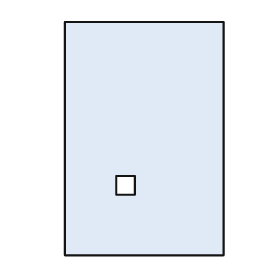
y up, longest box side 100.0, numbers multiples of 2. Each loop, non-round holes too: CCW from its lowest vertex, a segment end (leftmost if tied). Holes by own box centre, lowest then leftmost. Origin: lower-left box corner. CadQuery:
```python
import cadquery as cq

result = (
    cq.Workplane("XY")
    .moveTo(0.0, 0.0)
    .lineTo(68.0, 0.0)
    .lineTo(68.0, 100.0)
    .lineTo(0.0, 100.0)
    .close()
    .moveTo(22.0, 26.0)
    .lineTo(30.0, 26.0)
    .lineTo(30.0, 34.0)
    .lineTo(22.0, 34.0)
    .close()
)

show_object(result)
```